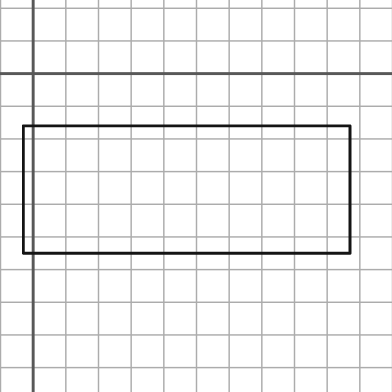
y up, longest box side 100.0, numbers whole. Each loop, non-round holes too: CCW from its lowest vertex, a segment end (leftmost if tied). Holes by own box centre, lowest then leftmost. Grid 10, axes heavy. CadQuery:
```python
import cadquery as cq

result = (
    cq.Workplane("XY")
    .moveTo(-3.0, -55.0)
    .lineTo(97.0, -55.0)
    .lineTo(97.0, -16.0)
    .lineTo(-3.0, -16.0)
    .close()
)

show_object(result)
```